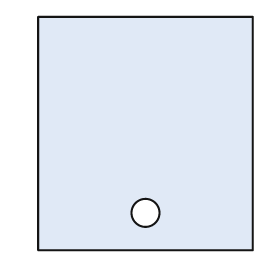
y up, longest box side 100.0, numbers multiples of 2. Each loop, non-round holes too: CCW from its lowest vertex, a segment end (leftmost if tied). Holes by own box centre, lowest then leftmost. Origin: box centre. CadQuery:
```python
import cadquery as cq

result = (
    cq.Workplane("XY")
    .moveTo(-46.0, -50.0)
    .lineTo(46.0, -50.0)
    .lineTo(46.0, 50.0)
    .lineTo(-46.0, 50.0)
    .close()
    .moveTo(0.0, -34.0)
    .circle(6.0)
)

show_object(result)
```